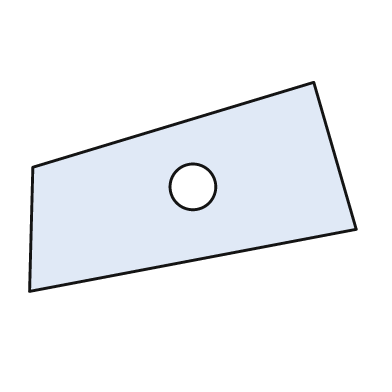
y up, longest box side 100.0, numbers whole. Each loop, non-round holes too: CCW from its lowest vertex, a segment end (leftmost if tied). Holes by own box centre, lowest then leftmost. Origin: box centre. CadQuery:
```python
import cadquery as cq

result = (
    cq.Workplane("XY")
    .moveTo(-50.0, -32.0)
    .lineTo(50.0, -13.0)
    .lineTo(37.0, 32.0)
    .lineTo(-49.0, 6.0)
    .close()
    .moveTo(0.0, 0.0)
    .circle(7.0)
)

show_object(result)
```